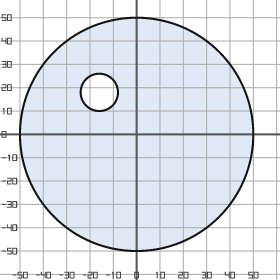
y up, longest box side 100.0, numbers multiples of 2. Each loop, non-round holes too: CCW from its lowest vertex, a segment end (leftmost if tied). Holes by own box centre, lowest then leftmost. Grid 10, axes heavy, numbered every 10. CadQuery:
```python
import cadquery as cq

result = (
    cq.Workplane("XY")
    .moveTo(0.0, 0.0)
    .circle(50.0)
    .moveTo(-16.0, 18.0)
    .circle(8.0)
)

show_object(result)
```